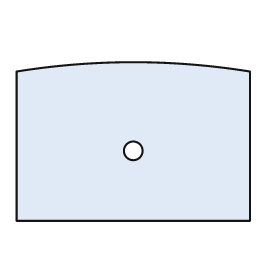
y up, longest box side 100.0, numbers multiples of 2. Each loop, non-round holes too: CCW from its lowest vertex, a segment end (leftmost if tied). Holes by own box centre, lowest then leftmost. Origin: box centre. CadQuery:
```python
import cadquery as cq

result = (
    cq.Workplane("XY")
    .moveTo(-50.0, -34.0)
    .lineTo(50.0, -34.0)
    .lineTo(50.0, 30.0)
    .threePointArc((0.0, 34.0), (-50.0, 30.0))
    .close()
    .moveTo(0.0, -4.0)
    .circle(4.0)
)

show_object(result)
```